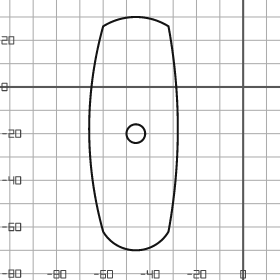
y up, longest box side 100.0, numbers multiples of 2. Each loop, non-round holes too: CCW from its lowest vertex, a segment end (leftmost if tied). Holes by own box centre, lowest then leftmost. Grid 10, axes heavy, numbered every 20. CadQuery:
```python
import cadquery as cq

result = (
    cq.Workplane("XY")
    .moveTo(-60.0, -62.0)
    .threePointArc((-46.0, -70.0), (-32.0, -62.0))
    .threePointArc((-28.0, -18.0), (-32.0, 26.0))
    .threePointArc((-46.0, 30.0), (-60.0, 26.0))
    .threePointArc((-66.0, -18.0), (-60.0, -62.0))
    .close()
    .moveTo(-46.0, -20.0)
    .circle(4.0)
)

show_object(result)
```